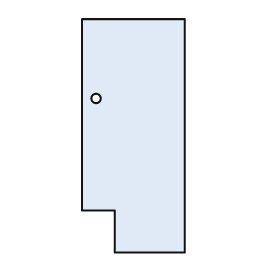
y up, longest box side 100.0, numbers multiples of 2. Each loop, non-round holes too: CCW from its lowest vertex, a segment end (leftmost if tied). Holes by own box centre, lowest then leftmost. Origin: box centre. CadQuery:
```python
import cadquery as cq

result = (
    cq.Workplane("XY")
    .moveTo(-8.0, -50.0)
    .lineTo(22.0, -50.0)
    .lineTo(22.0, 50.0)
    .lineTo(-22.0, 50.0)
    .lineTo(-22.0, -32.0)
    .lineTo(-8.0, -32.0)
    .close()
    .moveTo(-16.0, 16.0)
    .circle(2.0)
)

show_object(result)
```